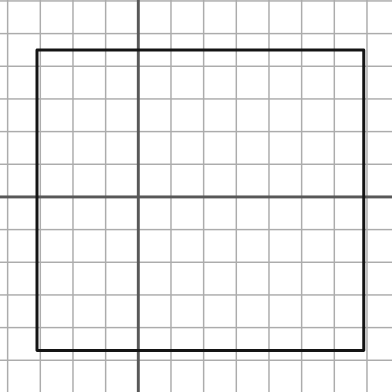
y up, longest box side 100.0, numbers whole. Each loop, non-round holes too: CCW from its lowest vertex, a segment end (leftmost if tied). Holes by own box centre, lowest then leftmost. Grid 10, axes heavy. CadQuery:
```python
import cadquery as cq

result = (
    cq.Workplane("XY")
    .moveTo(-31.0, -47.0)
    .lineTo(69.0, -47.0)
    .lineTo(69.0, 45.0)
    .lineTo(-31.0, 45.0)
    .close()
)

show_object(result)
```